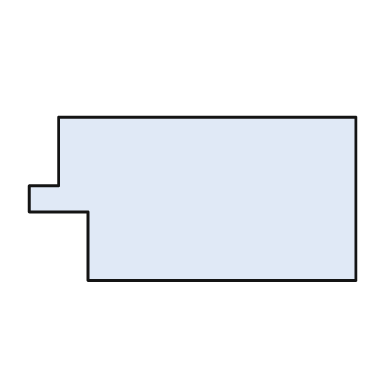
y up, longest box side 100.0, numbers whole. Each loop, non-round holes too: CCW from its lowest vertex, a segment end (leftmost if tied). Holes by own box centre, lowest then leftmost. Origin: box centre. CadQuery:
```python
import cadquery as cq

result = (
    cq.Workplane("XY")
    .moveTo(-32.0, -25.0)
    .lineTo(50.0, -25.0)
    .lineTo(50.0, 25.0)
    .lineTo(-41.0, 25.0)
    .lineTo(-41.0, 4.0)
    .lineTo(-50.0, 4.0)
    .lineTo(-50.0, -4.0)
    .lineTo(-32.0, -4.0)
    .close()
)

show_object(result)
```